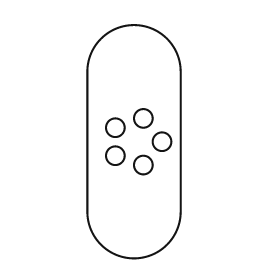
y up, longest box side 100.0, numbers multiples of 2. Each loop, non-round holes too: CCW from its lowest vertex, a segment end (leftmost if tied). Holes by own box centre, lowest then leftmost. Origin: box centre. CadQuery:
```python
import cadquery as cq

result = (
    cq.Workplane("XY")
    .moveTo(-20.0, -30.0)
    .threePointArc((0.0, -50.0), (20.0, -30.0))
    .lineTo(20.0, 30.0)
    .threePointArc((0.0, 50.0), (-20.0, 30.0))
    .close()
    .moveTo(4.0, -10.0)
    .circle(4.0)
    .moveTo(-8.0, -6.0)
    .circle(4.0)
    .moveTo(12.0, 0.0)
    .circle(4.0)
    .moveTo(-8.0, 6.0)
    .circle(4.0)
    .moveTo(4.0, 10.0)
    .circle(4.0)
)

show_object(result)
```